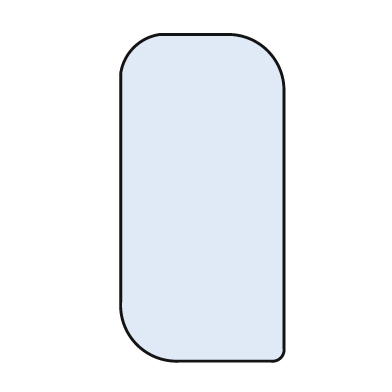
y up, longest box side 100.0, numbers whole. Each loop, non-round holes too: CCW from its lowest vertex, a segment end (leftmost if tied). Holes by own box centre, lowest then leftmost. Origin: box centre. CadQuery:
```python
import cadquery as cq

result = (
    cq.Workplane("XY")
    .moveTo(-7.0, -50.0)
    .lineTo(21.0, -50.0)
    .threePointArc((24.0, -49.0), (25.0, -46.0))
    .lineTo(25.0, 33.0)
    .threePointArc((20.0, 45.0), (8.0, 50.0))
    .lineTo(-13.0, 50.0)
    .threePointArc((-21.0, 46.0), (-25.0, 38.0))
    .lineTo(-25.0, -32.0)
    .threePointArc((-20.0, -45.0), (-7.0, -50.0))
    .close()
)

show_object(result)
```